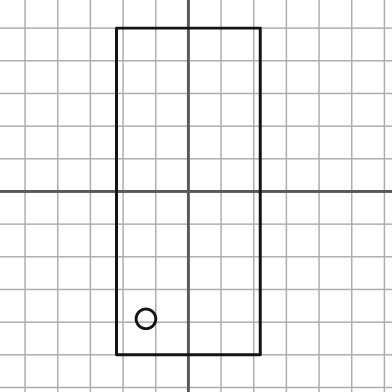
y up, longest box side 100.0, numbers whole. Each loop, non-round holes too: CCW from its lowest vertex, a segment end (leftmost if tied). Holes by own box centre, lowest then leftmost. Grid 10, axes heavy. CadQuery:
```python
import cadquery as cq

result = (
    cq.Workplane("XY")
    .moveTo(-22.0, -50.0)
    .lineTo(22.0, -50.0)
    .lineTo(22.0, 50.0)
    .lineTo(-22.0, 50.0)
    .close()
    .moveTo(-13.0, -39.0)
    .circle(3.0)
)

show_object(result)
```